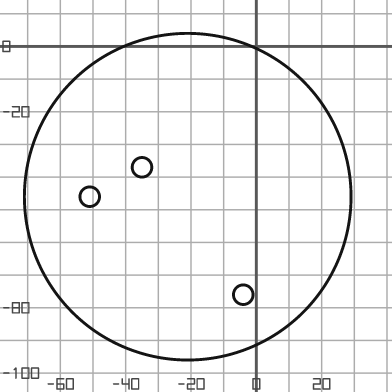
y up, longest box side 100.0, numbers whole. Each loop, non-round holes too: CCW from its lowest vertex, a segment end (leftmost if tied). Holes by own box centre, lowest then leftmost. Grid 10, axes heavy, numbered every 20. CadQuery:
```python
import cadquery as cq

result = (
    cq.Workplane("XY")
    .moveTo(-21.0, -46.0)
    .circle(50.0)
    .moveTo(-4.0, -76.0)
    .circle(3.0)
    .moveTo(-51.0, -46.0)
    .circle(3.0)
    .moveTo(-35.0, -37.0)
    .circle(3.0)
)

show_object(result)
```